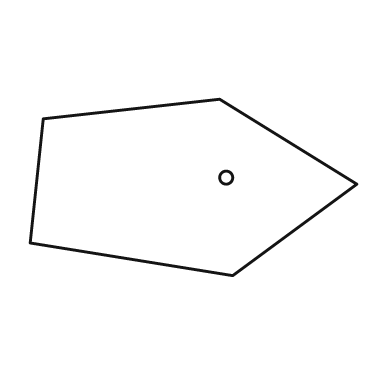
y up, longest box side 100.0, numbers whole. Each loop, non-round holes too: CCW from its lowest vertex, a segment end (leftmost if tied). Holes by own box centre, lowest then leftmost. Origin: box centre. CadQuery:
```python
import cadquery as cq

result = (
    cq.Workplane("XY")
    .moveTo(12.0, -27.0)
    .lineTo(50.0, 1.0)
    .lineTo(8.0, 27.0)
    .lineTo(-46.0, 21.0)
    .lineTo(-50.0, -17.0)
    .close()
    .moveTo(10.0, 3.0)
    .circle(2.0)
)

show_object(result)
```